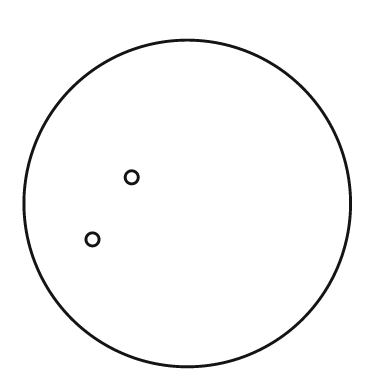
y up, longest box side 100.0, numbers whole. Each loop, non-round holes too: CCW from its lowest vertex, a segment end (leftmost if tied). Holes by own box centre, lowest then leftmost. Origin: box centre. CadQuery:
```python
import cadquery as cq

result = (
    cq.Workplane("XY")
    .moveTo(0.0, 0.0)
    .circle(50.0)
    .moveTo(-29.0, -11.0)
    .circle(2.0)
    .moveTo(-17.0, 8.0)
    .circle(2.0)
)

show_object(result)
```